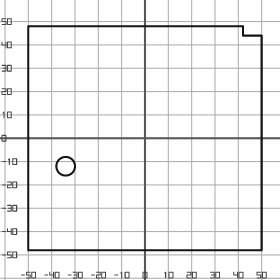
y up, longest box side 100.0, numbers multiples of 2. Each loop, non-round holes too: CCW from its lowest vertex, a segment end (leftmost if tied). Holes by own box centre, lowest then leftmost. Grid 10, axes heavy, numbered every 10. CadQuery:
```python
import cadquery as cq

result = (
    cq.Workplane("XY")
    .moveTo(-50.0, -48.0)
    .lineTo(50.0, -48.0)
    .lineTo(50.0, 44.0)
    .lineTo(42.0, 44.0)
    .lineTo(42.0, 48.0)
    .lineTo(-50.0, 48.0)
    .close()
    .moveTo(-34.0, -12.0)
    .circle(4.0)
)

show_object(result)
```